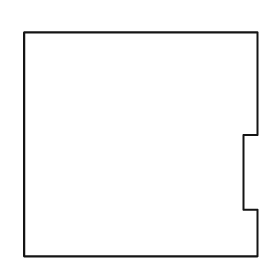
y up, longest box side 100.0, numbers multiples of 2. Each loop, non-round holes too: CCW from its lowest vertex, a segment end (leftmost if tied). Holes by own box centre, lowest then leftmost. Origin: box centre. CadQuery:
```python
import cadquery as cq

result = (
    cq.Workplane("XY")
    .moveTo(-50.0, -48.0)
    .lineTo(50.0, -48.0)
    .lineTo(50.0, -28.0)
    .lineTo(44.0, -28.0)
    .lineTo(44.0, 4.0)
    .lineTo(50.0, 4.0)
    .lineTo(50.0, 48.0)
    .lineTo(-50.0, 48.0)
    .close()
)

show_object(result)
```